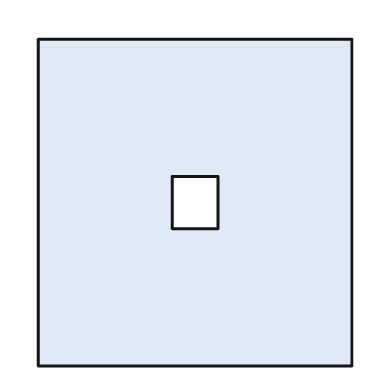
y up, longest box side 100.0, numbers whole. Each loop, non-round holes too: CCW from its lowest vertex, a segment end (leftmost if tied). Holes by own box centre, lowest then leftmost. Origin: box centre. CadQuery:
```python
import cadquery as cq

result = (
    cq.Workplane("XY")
    .moveTo(-48.0, -50.0)
    .lineTo(48.0, -50.0)
    .lineTo(48.0, 50.0)
    .lineTo(-48.0, 50.0)
    .close()
    .moveTo(-7.0, -8.0)
    .lineTo(7.0, -8.0)
    .lineTo(7.0, 8.0)
    .lineTo(-7.0, 8.0)
    .close()
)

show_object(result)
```